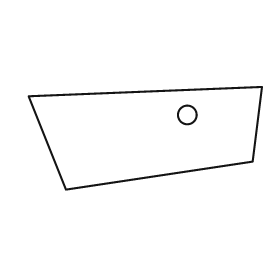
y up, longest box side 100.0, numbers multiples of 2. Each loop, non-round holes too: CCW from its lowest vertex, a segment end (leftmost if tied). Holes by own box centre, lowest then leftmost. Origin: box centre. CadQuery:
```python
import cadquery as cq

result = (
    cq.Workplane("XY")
    .moveTo(-34.0, -22.0)
    .lineTo(46.0, -10.0)
    .lineTo(50.0, 22.0)
    .lineTo(-50.0, 18.0)
    .close()
    .moveTo(18.0, 10.0)
    .circle(4.0)
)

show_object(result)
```